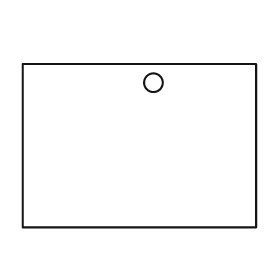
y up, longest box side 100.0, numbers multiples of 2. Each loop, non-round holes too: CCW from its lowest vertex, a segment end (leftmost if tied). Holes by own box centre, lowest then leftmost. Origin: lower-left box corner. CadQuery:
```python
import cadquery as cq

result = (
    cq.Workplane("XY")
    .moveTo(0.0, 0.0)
    .lineTo(100.0, 0.0)
    .lineTo(100.0, 70.0)
    .lineTo(0.0, 70.0)
    .close()
    .moveTo(56.0, 62.0)
    .circle(4.0)
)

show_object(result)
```